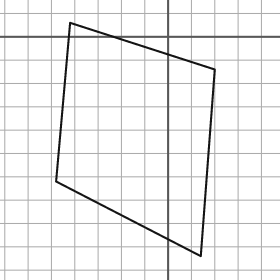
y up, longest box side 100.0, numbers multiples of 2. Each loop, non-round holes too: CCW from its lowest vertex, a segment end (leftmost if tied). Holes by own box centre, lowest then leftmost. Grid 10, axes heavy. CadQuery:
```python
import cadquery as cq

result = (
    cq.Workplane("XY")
    .moveTo(14.0, -94.0)
    .lineTo(20.0, -14.0)
    .lineTo(-42.0, 6.0)
    .lineTo(-48.0, -62.0)
    .close()
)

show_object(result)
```